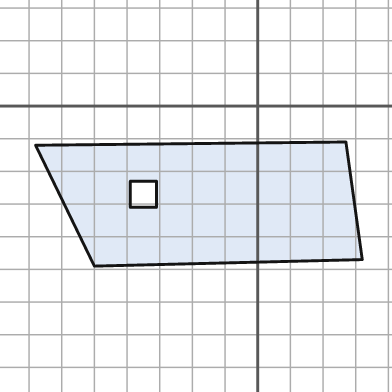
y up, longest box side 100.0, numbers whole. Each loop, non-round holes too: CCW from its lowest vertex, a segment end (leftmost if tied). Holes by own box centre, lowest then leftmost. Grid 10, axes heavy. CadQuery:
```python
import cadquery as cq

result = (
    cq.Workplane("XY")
    .moveTo(-50.0, -49.0)
    .lineTo(32.0, -47.0)
    .lineTo(27.0, -11.0)
    .lineTo(-68.0, -12.0)
    .close()
    .moveTo(-39.0, -31.0)
    .lineTo(-31.0, -31.0)
    .lineTo(-31.0, -23.0)
    .lineTo(-39.0, -23.0)
    .close()
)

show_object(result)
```